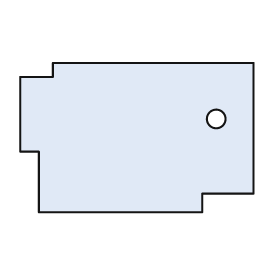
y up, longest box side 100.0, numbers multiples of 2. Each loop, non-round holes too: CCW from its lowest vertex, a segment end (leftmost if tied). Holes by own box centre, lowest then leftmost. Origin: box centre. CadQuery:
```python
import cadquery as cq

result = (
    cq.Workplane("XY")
    .moveTo(-42.0, -32.0)
    .lineTo(28.0, -32.0)
    .lineTo(28.0, -24.0)
    .lineTo(50.0, -24.0)
    .lineTo(50.0, 32.0)
    .lineTo(-36.0, 32.0)
    .lineTo(-36.0, 26.0)
    .lineTo(-50.0, 26.0)
    .lineTo(-50.0, -6.0)
    .lineTo(-42.0, -6.0)
    .close()
    .moveTo(34.0, 8.0)
    .circle(4.0)
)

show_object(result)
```